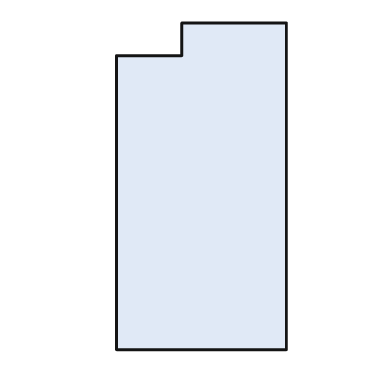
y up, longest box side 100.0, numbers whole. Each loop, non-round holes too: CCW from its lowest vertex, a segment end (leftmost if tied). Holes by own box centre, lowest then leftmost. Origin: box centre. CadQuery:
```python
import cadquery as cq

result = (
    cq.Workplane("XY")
    .moveTo(-26.0, -50.0)
    .lineTo(26.0, -50.0)
    .lineTo(26.0, 50.0)
    .lineTo(-6.0, 50.0)
    .lineTo(-6.0, 40.0)
    .lineTo(-26.0, 40.0)
    .close()
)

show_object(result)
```